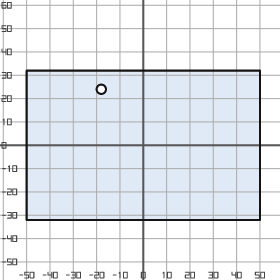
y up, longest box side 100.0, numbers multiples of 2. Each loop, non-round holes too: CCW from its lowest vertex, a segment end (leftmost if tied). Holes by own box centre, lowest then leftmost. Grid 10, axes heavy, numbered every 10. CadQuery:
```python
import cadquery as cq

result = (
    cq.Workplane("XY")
    .moveTo(-50.0, -32.0)
    .lineTo(50.0, -32.0)
    .lineTo(50.0, 32.0)
    .lineTo(-50.0, 32.0)
    .close()
    .moveTo(-18.0, 24.0)
    .circle(2.0)
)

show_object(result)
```